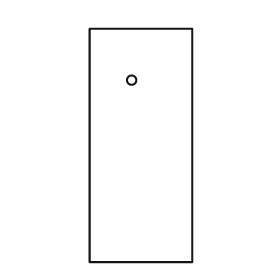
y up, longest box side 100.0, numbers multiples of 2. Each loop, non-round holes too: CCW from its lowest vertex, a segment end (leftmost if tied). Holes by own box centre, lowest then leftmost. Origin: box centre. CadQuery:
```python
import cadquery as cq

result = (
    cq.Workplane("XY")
    .moveTo(-22.0, -50.0)
    .lineTo(22.0, -50.0)
    .lineTo(22.0, 50.0)
    .lineTo(-22.0, 50.0)
    .close()
    .moveTo(-4.0, 28.0)
    .circle(2.0)
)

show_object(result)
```